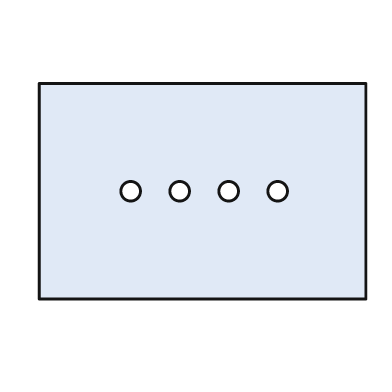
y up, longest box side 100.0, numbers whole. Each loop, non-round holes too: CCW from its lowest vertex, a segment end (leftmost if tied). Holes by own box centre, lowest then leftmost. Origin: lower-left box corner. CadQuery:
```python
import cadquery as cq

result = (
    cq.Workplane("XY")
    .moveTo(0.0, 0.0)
    .lineTo(100.0, 0.0)
    .lineTo(100.0, 66.0)
    .lineTo(0.0, 66.0)
    .close()
    .moveTo(28.0, 33.0)
    .circle(3.0)
    .moveTo(43.0, 33.0)
    .circle(3.0)
    .moveTo(58.0, 33.0)
    .circle(3.0)
    .moveTo(73.0, 33.0)
    .circle(3.0)
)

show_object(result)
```